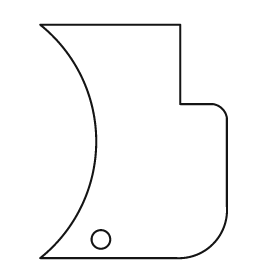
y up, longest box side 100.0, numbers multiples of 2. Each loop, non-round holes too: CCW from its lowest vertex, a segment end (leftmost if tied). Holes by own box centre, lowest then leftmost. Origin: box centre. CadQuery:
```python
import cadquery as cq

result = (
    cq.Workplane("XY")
    .moveTo(-40.0, -50.0)
    .lineTo(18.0, -50.0)
    .threePointArc((34.0, -44.0), (40.0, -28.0))
    .lineTo(40.0, 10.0)
    .threePointArc((38.0, 14.0), (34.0, 16.0))
    .lineTo(20.0, 16.0)
    .lineTo(20.0, 50.0)
    .lineTo(-40.0, 50.0)
    .threePointArc((-16.0, 0.0), (-40.0, -50.0))
    .close()
    .moveTo(-14.0, -42.0)
    .circle(4.0)
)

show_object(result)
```